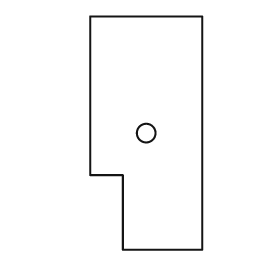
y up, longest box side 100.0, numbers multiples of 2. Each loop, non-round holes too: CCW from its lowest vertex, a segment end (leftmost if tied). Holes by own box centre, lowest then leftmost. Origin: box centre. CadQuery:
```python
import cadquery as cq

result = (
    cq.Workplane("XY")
    .moveTo(-10.0, -50.0)
    .lineTo(24.0, -50.0)
    .lineTo(24.0, 50.0)
    .lineTo(-24.0, 50.0)
    .lineTo(-24.0, -18.0)
    .lineTo(-10.0, -18.0)
    .close()
    .moveTo(0.0, 0.0)
    .circle(4.0)
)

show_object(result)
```